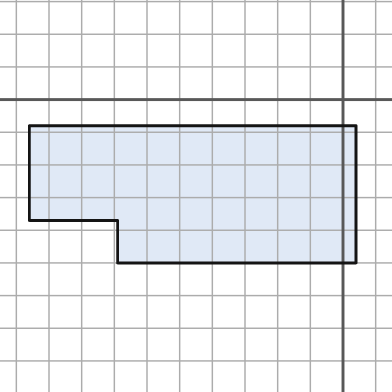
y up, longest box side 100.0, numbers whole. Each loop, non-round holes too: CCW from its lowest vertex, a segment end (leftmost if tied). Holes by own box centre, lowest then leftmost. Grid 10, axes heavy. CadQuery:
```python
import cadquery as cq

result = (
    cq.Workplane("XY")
    .moveTo(-69.0, -50.0)
    .lineTo(4.0, -50.0)
    .lineTo(4.0, -8.0)
    .lineTo(-96.0, -8.0)
    .lineTo(-96.0, -37.0)
    .lineTo(-69.0, -37.0)
    .close()
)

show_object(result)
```